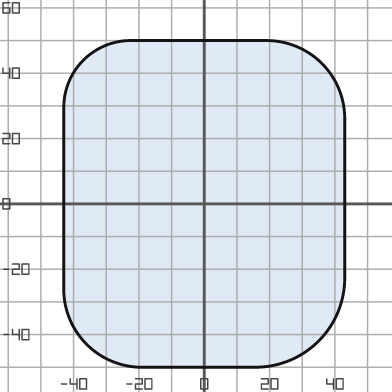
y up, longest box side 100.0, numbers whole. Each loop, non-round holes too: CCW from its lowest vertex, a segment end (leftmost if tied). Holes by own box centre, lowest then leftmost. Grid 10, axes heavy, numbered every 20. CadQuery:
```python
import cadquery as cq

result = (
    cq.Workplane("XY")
    .moveTo(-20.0, -50.0)
    .lineTo(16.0, -50.0)
    .threePointArc((35.0, -42.0), (43.0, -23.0))
    .lineTo(43.0, 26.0)
    .threePointArc((36.0, 43.0), (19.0, 50.0))
    .lineTo(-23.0, 50.0)
    .threePointArc((-37.0, 44.0), (-43.0, 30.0))
    .lineTo(-43.0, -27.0)
    .threePointArc((-36.0, -43.0), (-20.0, -50.0))
    .close()
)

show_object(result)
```